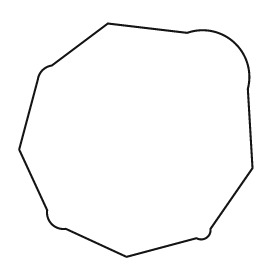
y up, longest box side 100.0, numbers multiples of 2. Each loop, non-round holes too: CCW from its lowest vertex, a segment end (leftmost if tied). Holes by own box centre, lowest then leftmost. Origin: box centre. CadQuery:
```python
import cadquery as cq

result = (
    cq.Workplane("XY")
    .moveTo(-4.0, -50.0)
    .lineTo(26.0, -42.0)
    .threePointArc((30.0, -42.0), (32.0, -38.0))
    .lineTo(50.0, -12.0)
    .lineTo(48.0, 22.0)
    .threePointArc((42.0, 42.0), (22.0, 46.0))
    .lineTo(-12.0, 50.0)
    .lineTo(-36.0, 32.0)
    .threePointArc((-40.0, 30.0), (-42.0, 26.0))
    .lineTo(-50.0, -4.0)
    .lineTo(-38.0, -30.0)
    .threePointArc((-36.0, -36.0), (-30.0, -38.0))
    .close()
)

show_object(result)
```